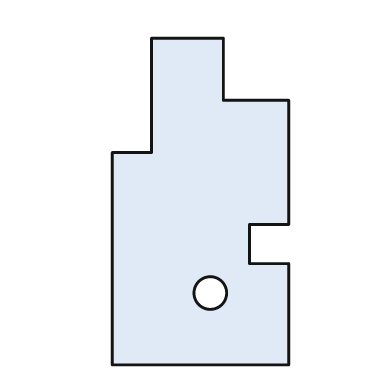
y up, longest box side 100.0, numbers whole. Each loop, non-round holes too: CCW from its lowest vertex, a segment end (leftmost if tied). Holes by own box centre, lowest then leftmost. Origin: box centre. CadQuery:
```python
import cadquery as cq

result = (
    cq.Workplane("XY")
    .moveTo(-27.0, -50.0)
    .lineTo(27.0, -50.0)
    .lineTo(27.0, -19.0)
    .lineTo(15.0, -19.0)
    .lineTo(15.0, -7.0)
    .lineTo(27.0, -7.0)
    .lineTo(27.0, 31.0)
    .lineTo(7.0, 31.0)
    .lineTo(7.0, 50.0)
    .lineTo(-15.0, 50.0)
    .lineTo(-15.0, 15.0)
    .lineTo(-27.0, 15.0)
    .close()
    .moveTo(3.0, -28.0)
    .circle(5.0)
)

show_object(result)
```